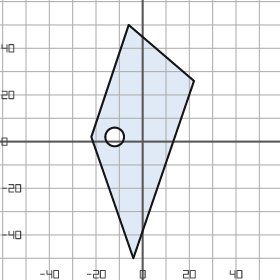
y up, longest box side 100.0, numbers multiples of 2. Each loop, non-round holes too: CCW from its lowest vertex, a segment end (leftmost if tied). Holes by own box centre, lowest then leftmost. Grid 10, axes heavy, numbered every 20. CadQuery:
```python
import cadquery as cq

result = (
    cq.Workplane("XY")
    .moveTo(-4.0, -50.0)
    .lineTo(22.0, 26.0)
    .lineTo(-6.0, 50.0)
    .lineTo(-22.0, 2.0)
    .close()
    .moveTo(-12.0, 2.0)
    .circle(4.0)
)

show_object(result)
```